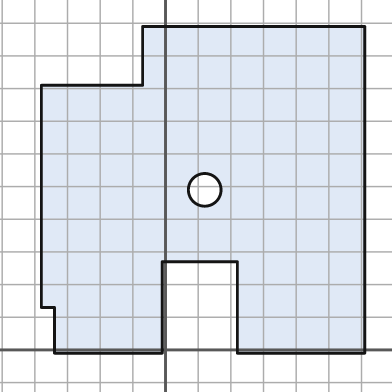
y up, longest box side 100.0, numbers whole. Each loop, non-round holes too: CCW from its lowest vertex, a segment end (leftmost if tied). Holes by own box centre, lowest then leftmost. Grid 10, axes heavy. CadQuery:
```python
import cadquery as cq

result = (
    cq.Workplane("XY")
    .moveTo(-34.0, -1.0)
    .lineTo(-1.0, -1.0)
    .lineTo(-1.0, 27.0)
    .lineTo(22.0, 27.0)
    .lineTo(22.0, -1.0)
    .lineTo(61.0, -1.0)
    .lineTo(61.0, 99.0)
    .lineTo(-7.0, 99.0)
    .lineTo(-7.0, 81.0)
    .lineTo(-38.0, 81.0)
    .lineTo(-38.0, 13.0)
    .lineTo(-34.0, 13.0)
    .close()
    .moveTo(12.0, 49.0)
    .circle(5.0)
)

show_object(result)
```